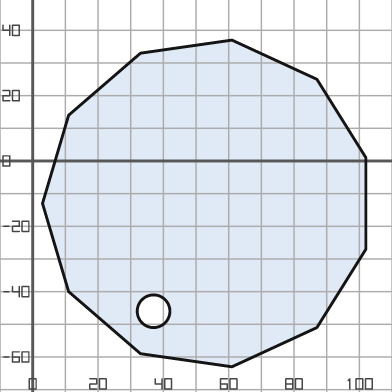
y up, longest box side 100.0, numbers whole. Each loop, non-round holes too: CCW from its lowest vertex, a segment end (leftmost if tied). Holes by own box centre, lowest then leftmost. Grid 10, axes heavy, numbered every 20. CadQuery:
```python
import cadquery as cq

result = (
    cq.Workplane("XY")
    .moveTo(61.0, -63.0)
    .lineTo(87.0, -51.0)
    .lineTo(102.0, -27.0)
    .lineTo(102.0, 1.0)
    .lineTo(87.0, 25.0)
    .lineTo(61.0, 37.0)
    .lineTo(33.0, 33.0)
    .lineTo(11.0, 14.0)
    .lineTo(3.0, -13.0)
    .lineTo(11.0, -40.0)
    .lineTo(33.0, -59.0)
    .close()
    .moveTo(37.0, -46.0)
    .circle(5.0)
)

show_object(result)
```